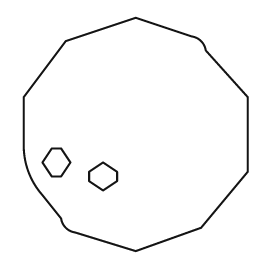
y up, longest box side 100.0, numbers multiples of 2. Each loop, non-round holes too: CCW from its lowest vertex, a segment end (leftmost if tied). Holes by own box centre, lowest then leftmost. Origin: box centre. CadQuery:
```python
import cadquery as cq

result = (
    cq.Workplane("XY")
    .moveTo(0.0, -50.0)
    .lineTo(28.0, -40.0)
    .lineTo(48.0, -16.0)
    .lineTo(48.0, 16.0)
    .lineTo(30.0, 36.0)
    .threePointArc((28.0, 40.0), (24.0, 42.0))
    .lineTo(0.0, 50.0)
    .lineTo(-30.0, 40.0)
    .lineTo(-48.0, 16.0)
    .lineTo(-48.0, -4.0)
    .threePointArc((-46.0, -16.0), (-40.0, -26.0))
    .lineTo(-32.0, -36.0)
    .threePointArc((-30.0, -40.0), (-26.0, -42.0))
    .close()
    .moveTo(-14.0, -24.0)
    .lineTo(-8.0, -20.0)
    .lineTo(-8.0, -16.0)
    .lineTo(-14.0, -12.0)
    .lineTo(-20.0, -16.0)
    .lineTo(-20.0, -20.0)
    .close()
    .moveTo(-36.0, -18.0)
    .lineTo(-32.0, -18.0)
    .lineTo(-28.0, -12.0)
    .lineTo(-32.0, -6.0)
    .lineTo(-36.0, -6.0)
    .lineTo(-40.0, -12.0)
    .close()
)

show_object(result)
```